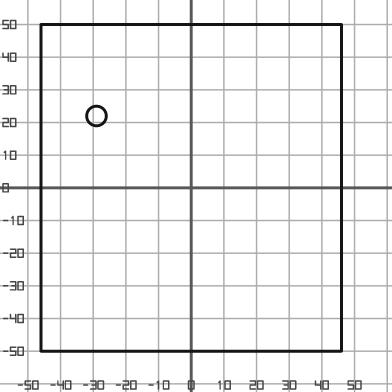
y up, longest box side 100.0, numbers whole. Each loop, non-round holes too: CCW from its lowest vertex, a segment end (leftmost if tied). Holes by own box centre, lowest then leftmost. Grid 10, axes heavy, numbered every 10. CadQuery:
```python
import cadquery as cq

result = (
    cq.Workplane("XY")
    .moveTo(-46.0, -50.0)
    .lineTo(46.0, -50.0)
    .lineTo(46.0, 50.0)
    .lineTo(-46.0, 50.0)
    .close()
    .moveTo(-29.0, 22.0)
    .circle(3.0)
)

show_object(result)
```